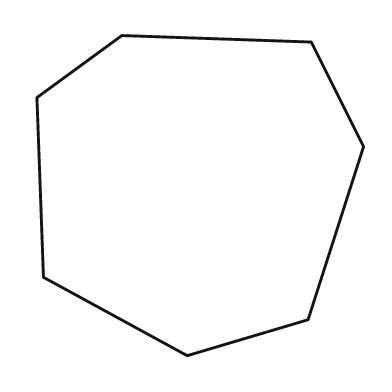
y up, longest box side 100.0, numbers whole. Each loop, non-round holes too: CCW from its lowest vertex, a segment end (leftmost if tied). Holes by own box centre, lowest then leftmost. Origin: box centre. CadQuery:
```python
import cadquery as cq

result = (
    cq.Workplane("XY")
    .moveTo(-4.0, -49.0)
    .lineTo(33.0, -38.0)
    .lineTo(50.0, 15.0)
    .lineTo(34.0, 47.0)
    .lineTo(-24.0, 49.0)
    .lineTo(-50.0, 30.0)
    .lineTo(-48.0, -25.0)
    .close()
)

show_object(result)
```